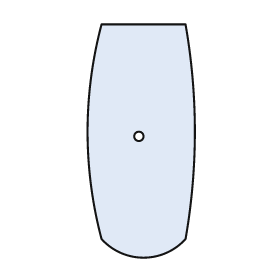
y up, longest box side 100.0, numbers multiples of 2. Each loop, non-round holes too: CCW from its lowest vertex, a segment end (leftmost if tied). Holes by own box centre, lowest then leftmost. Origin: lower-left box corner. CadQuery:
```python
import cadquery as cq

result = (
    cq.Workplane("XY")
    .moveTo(6.0, 8.0)
    .threePointArc((24.0, 0.0), (42.0, 8.0))
    .threePointArc((46.0, 54.0), (42.0, 100.0))
    .lineTo(6.0, 100.0)
    .threePointArc((0.0, 54.0), (6.0, 8.0))
    .close()
    .moveTo(22.0, 52.0)
    .circle(2.0)
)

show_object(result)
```